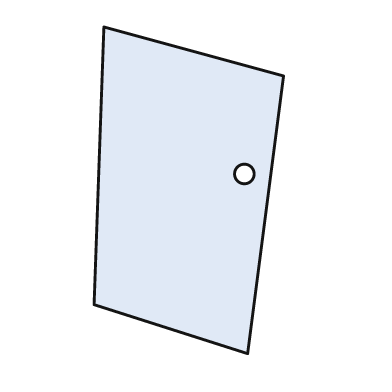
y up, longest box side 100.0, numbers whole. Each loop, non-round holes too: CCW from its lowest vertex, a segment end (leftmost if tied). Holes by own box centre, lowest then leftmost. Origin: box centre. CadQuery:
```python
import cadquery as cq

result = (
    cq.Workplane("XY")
    .moveTo(18.0, -50.0)
    .lineTo(29.0, 35.0)
    .lineTo(-26.0, 50.0)
    .lineTo(-29.0, -35.0)
    .close()
    .moveTo(17.0, 5.0)
    .circle(3.0)
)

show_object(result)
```